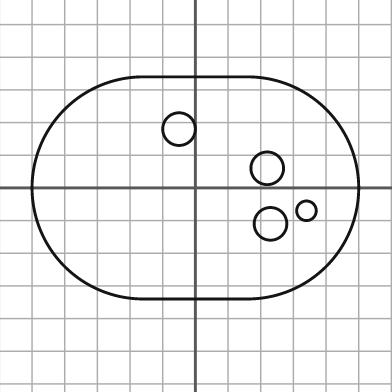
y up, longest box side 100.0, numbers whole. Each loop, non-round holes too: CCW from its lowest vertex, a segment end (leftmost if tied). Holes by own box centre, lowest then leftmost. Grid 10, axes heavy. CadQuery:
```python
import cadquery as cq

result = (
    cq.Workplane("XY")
    .moveTo(-16.0, -34.0)
    .lineTo(16.0, -34.0)
    .threePointArc((50.0, 0.0), (16.0, 34.0))
    .lineTo(-16.0, 34.0)
    .threePointArc((-50.0, 0.0), (-16.0, -34.0))
    .close()
    .moveTo(23.0, -11.0)
    .circle(5.0)
    .moveTo(34.0, -7.0)
    .circle(3.0)
    .moveTo(22.0, 6.0)
    .circle(5.0)
    .moveTo(-5.0, 18.0)
    .circle(5.0)
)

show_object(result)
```